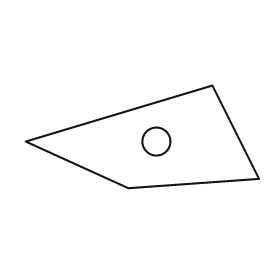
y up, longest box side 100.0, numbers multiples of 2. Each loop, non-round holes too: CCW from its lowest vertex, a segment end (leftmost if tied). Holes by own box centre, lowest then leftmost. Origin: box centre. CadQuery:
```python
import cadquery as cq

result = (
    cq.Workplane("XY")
    .moveTo(-6.0, -22.0)
    .lineTo(50.0, -18.0)
    .lineTo(30.0, 22.0)
    .lineTo(-50.0, -2.0)
    .close()
    .moveTo(6.0, -2.0)
    .circle(6.0)
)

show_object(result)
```